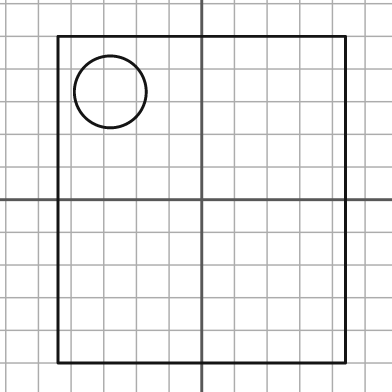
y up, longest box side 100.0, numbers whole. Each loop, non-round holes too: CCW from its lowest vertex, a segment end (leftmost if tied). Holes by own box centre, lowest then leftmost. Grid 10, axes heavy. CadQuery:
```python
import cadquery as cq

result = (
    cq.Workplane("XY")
    .moveTo(-44.0, -50.0)
    .lineTo(44.0, -50.0)
    .lineTo(44.0, 50.0)
    .lineTo(-44.0, 50.0)
    .close()
    .moveTo(-28.0, 33.0)
    .circle(11.0)
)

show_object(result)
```